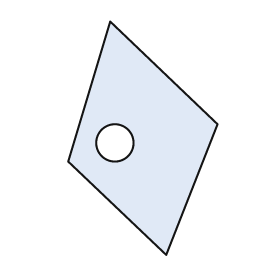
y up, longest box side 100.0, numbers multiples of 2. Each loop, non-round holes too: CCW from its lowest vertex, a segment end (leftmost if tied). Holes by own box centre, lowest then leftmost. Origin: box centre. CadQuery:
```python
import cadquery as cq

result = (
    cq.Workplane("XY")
    .moveTo(10.0, -50.0)
    .lineTo(32.0, 6.0)
    .lineTo(-14.0, 50.0)
    .lineTo(-32.0, -10.0)
    .close()
    .moveTo(-12.0, -2.0)
    .circle(8.0)
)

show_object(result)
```